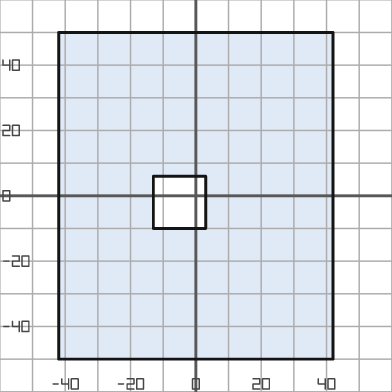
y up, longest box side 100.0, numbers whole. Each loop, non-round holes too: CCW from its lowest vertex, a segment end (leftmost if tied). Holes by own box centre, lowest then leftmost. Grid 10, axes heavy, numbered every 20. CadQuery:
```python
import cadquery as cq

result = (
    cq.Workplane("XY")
    .moveTo(-42.0, -50.0)
    .lineTo(42.0, -50.0)
    .lineTo(42.0, 50.0)
    .lineTo(-42.0, 50.0)
    .close()
    .moveTo(-13.0, -10.0)
    .lineTo(3.0, -10.0)
    .lineTo(3.0, 6.0)
    .lineTo(-13.0, 6.0)
    .close()
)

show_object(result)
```